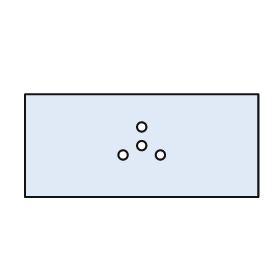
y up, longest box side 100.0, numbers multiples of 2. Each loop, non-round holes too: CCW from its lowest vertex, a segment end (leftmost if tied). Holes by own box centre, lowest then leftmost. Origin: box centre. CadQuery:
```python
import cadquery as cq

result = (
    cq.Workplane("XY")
    .moveTo(-50.0, -22.0)
    .lineTo(50.0, -22.0)
    .lineTo(50.0, 22.0)
    .lineTo(-50.0, 22.0)
    .close()
    .moveTo(-8.0, -4.0)
    .circle(2.0)
    .moveTo(8.0, -4.0)
    .circle(2.0)
    .moveTo(0.0, 0.0)
    .circle(2.0)
    .moveTo(0.0, 8.0)
    .circle(2.0)
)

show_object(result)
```